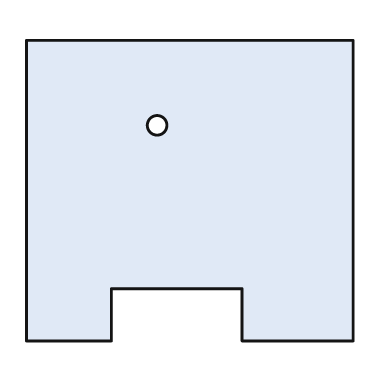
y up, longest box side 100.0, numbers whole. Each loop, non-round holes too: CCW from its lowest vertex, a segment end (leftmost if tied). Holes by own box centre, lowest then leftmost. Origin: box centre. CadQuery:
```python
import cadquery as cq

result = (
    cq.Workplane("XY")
    .moveTo(-50.0, -46.0)
    .lineTo(-24.0, -46.0)
    .lineTo(-24.0, -30.0)
    .lineTo(16.0, -30.0)
    .lineTo(16.0, -46.0)
    .lineTo(50.0, -46.0)
    .lineTo(50.0, 46.0)
    .lineTo(-50.0, 46.0)
    .close()
    .moveTo(-10.0, 20.0)
    .circle(3.0)
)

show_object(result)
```